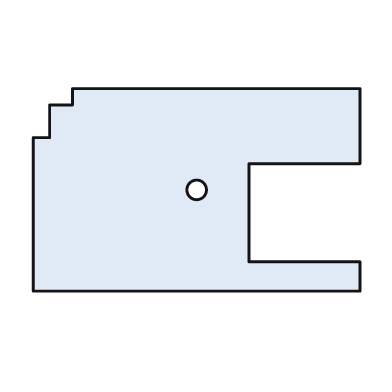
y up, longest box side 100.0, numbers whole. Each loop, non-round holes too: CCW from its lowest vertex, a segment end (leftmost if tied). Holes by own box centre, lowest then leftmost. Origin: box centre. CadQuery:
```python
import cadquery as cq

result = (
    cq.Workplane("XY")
    .moveTo(-50.0, -31.0)
    .lineTo(50.0, -31.0)
    .lineTo(50.0, -22.0)
    .lineTo(16.0, -22.0)
    .lineTo(16.0, 8.0)
    .lineTo(50.0, 8.0)
    .lineTo(50.0, 31.0)
    .lineTo(-38.0, 31.0)
    .lineTo(-38.0, 26.0)
    .lineTo(-45.0, 26.0)
    .lineTo(-45.0, 16.0)
    .lineTo(-50.0, 16.0)
    .close()
    .moveTo(0.0, 0.0)
    .circle(3.0)
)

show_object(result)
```